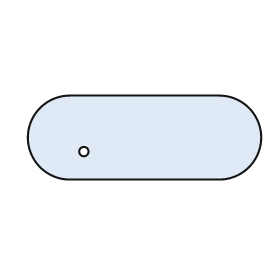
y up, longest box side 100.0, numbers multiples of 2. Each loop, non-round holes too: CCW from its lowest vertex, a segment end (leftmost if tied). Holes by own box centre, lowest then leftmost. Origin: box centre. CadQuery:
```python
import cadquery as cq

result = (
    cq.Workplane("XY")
    .moveTo(-32.0, -18.0)
    .lineTo(32.0, -18.0)
    .threePointArc((50.0, 0.0), (32.0, 18.0))
    .lineTo(-32.0, 18.0)
    .threePointArc((-50.0, 0.0), (-32.0, -18.0))
    .close()
    .moveTo(-26.0, -6.0)
    .circle(2.0)
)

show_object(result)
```